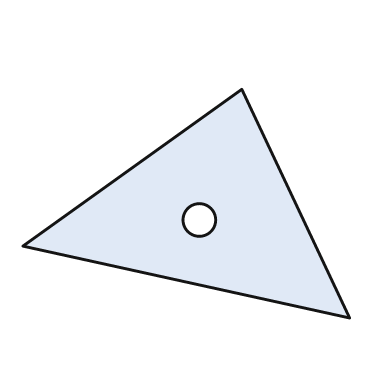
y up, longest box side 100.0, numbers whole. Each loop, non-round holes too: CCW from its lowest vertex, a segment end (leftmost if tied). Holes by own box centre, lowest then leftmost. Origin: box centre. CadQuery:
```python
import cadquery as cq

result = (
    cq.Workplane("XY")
    .moveTo(50.0, -35.0)
    .lineTo(17.0, 35.0)
    .lineTo(-50.0, -13.0)
    .close()
    .moveTo(4.0, -5.0)
    .circle(5.0)
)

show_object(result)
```